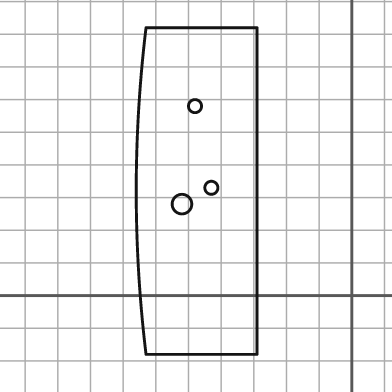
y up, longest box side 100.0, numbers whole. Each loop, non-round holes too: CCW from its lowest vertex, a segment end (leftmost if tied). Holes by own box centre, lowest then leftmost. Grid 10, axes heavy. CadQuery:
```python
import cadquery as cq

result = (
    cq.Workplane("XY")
    .moveTo(-63.0, -18.0)
    .lineTo(-29.0, -18.0)
    .lineTo(-29.0, 82.0)
    .lineTo(-63.0, 82.0)
    .threePointArc((-66.0, 32.0), (-63.0, -18.0))
    .close()
    .moveTo(-52.0, 28.0)
    .circle(3.0)
    .moveTo(-43.0, 33.0)
    .circle(2.0)
    .moveTo(-48.0, 58.0)
    .circle(2.0)
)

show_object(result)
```